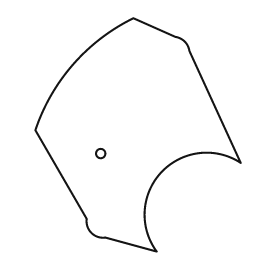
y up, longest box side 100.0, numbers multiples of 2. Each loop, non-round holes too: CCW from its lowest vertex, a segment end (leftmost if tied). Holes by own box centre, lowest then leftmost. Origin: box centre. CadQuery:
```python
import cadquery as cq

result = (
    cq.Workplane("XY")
    .moveTo(8.0, -50.0)
    .threePointArc((10.0, -16.0), (44.0, -12.0))
    .lineTo(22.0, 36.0)
    .threePointArc((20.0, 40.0), (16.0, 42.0))
    .lineTo(-2.0, 50.0)
    .threePointArc((-28.0, 30.0), (-44.0, 2.0))
    .lineTo(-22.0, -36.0)
    .threePointArc((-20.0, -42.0), (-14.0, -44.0))
    .close()
    .moveTo(-16.0, -8.0)
    .circle(2.0)
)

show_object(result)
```